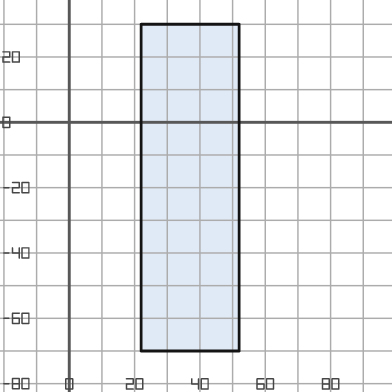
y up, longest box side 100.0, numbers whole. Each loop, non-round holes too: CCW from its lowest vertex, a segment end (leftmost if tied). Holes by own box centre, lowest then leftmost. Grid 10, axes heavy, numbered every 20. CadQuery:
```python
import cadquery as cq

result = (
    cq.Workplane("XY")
    .moveTo(22.0, -70.0)
    .lineTo(52.0, -70.0)
    .lineTo(52.0, 30.0)
    .lineTo(22.0, 30.0)
    .close()
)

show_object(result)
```